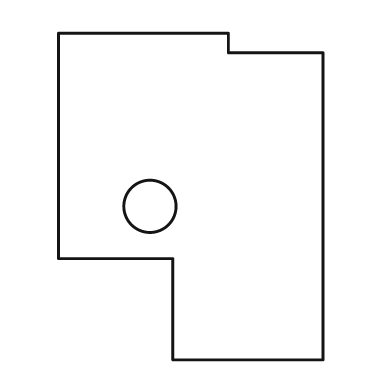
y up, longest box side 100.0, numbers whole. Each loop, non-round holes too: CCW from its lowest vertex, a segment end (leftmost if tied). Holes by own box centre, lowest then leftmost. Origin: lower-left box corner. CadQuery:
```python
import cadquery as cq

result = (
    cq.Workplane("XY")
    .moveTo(35.0, 0.0)
    .lineTo(81.0, 0.0)
    .lineTo(81.0, 94.0)
    .lineTo(52.0, 94.0)
    .lineTo(52.0, 100.0)
    .lineTo(0.0, 100.0)
    .lineTo(0.0, 31.0)
    .lineTo(35.0, 31.0)
    .close()
    .moveTo(28.0, 47.0)
    .circle(8.0)
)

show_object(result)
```